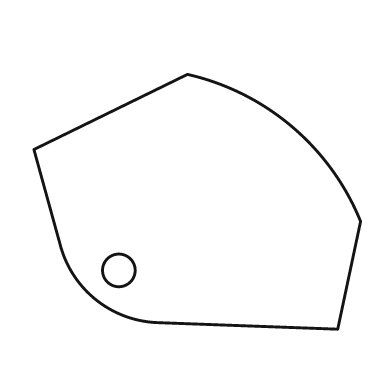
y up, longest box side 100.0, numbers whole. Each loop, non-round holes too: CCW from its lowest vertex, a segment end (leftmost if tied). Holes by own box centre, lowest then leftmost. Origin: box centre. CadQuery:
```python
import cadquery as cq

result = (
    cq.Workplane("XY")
    .moveTo(43.0, -39.0)
    .lineTo(50.0, -6.0)
    .threePointArc((29.0, 23.0), (-3.0, 39.0))
    .lineTo(-50.0, 16.0)
    .lineTo(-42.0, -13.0)
    .threePointArc((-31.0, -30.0), (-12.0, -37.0))
    .close()
    .moveTo(-24.0, -21.0)
    .circle(5.0)
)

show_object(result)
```